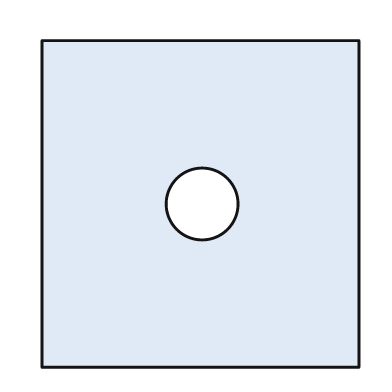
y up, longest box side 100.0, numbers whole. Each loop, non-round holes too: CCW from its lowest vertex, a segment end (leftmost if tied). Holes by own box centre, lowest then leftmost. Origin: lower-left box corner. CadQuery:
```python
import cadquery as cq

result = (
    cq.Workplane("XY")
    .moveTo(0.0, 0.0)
    .lineTo(97.0, 0.0)
    .lineTo(97.0, 100.0)
    .lineTo(0.0, 100.0)
    .close()
    .moveTo(49.0, 50.0)
    .circle(11.0)
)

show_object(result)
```